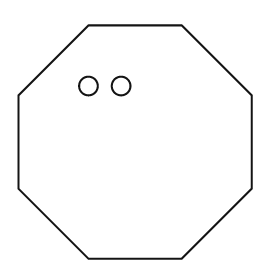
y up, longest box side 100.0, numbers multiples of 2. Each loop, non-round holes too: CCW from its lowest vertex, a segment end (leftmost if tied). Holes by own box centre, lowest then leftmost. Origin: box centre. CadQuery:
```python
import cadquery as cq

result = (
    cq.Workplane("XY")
    .moveTo(-20.0, -50.0)
    .lineTo(20.0, -50.0)
    .lineTo(50.0, -20.0)
    .lineTo(50.0, 20.0)
    .lineTo(20.0, 50.0)
    .lineTo(-20.0, 50.0)
    .lineTo(-50.0, 20.0)
    .lineTo(-50.0, -20.0)
    .close()
    .moveTo(-20.0, 24.0)
    .circle(4.0)
    .moveTo(-6.0, 24.0)
    .circle(4.0)
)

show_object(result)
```